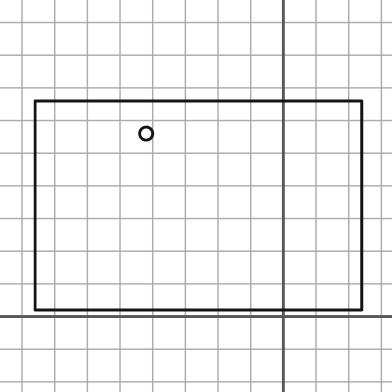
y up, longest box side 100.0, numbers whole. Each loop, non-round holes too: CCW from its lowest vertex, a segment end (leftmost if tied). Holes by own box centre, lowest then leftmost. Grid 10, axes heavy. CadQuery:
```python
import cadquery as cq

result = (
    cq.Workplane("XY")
    .moveTo(-76.0, 2.0)
    .lineTo(24.0, 2.0)
    .lineTo(24.0, 66.0)
    .lineTo(-76.0, 66.0)
    .close()
    .moveTo(-42.0, 56.0)
    .circle(2.0)
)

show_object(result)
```